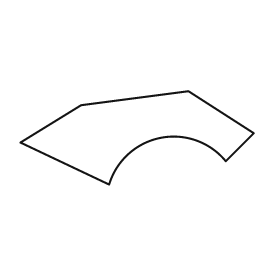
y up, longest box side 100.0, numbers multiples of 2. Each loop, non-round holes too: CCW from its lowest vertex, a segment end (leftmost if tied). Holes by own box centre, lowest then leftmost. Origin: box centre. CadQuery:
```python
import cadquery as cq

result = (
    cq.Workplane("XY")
    .moveTo(-12.0, -20.0)
    .threePointArc((10.0, 0.0), (38.0, -10.0))
    .lineTo(50.0, 2.0)
    .lineTo(22.0, 20.0)
    .lineTo(-24.0, 14.0)
    .lineTo(-50.0, -2.0)
    .close()
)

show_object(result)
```